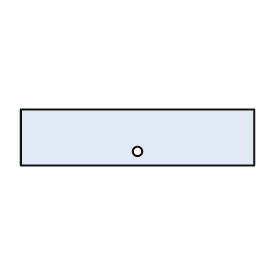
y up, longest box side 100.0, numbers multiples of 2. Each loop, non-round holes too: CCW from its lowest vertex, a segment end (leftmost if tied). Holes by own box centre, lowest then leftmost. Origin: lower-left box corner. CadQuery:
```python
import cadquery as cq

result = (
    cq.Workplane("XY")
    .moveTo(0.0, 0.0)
    .lineTo(100.0, 0.0)
    .lineTo(100.0, 24.0)
    .lineTo(0.0, 24.0)
    .close()
    .moveTo(50.0, 6.0)
    .circle(2.0)
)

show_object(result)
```